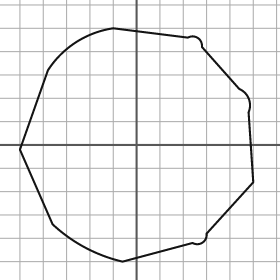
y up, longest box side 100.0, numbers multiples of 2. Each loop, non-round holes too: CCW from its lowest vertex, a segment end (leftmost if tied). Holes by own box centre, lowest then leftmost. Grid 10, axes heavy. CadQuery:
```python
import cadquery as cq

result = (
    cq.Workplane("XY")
    .moveTo(-6.0, -50.0)
    .lineTo(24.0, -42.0)
    .threePointArc((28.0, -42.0), (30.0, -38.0))
    .lineTo(50.0, -16.0)
    .lineTo(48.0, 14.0)
    .threePointArc((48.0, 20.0), (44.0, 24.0))
    .lineTo(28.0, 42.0)
    .threePointArc((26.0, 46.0), (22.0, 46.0))
    .lineTo(-10.0, 50.0)
    .threePointArc((-26.0, 44.0), (-38.0, 32.0))
    .lineTo(-50.0, -2.0)
    .lineTo(-36.0, -34.0)
    .threePointArc((-22.0, -44.0), (-6.0, -50.0))
    .close()
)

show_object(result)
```